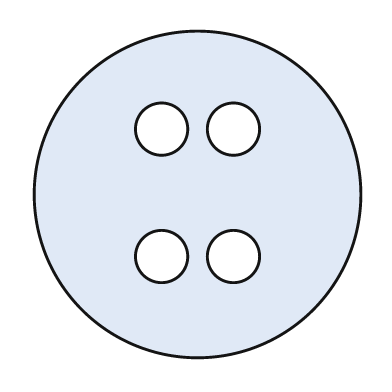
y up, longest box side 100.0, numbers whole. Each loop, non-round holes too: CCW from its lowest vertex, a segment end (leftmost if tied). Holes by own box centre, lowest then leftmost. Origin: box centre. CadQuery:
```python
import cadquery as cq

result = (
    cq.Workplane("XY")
    .moveTo(0.0, 0.0)
    .circle(50.0)
    .moveTo(-11.0, -19.0)
    .circle(8.0)
    .moveTo(11.0, -19.0)
    .circle(8.0)
    .moveTo(-11.0, 20.0)
    .circle(8.0)
    .moveTo(11.0, 20.0)
    .circle(8.0)
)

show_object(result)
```